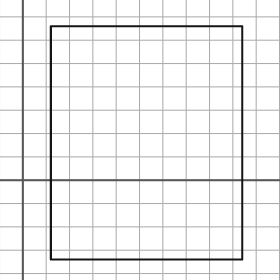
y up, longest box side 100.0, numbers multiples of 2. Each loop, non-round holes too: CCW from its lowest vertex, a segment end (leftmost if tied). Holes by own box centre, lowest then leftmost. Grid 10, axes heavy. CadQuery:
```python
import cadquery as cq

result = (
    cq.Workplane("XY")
    .moveTo(12.0, -34.0)
    .lineTo(94.0, -34.0)
    .lineTo(94.0, 66.0)
    .lineTo(12.0, 66.0)
    .close()
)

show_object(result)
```